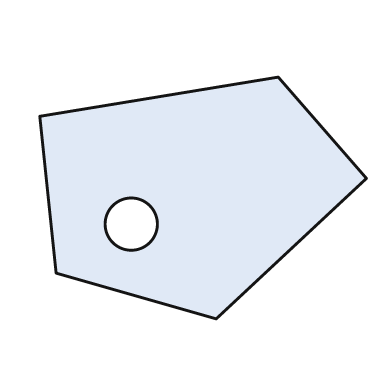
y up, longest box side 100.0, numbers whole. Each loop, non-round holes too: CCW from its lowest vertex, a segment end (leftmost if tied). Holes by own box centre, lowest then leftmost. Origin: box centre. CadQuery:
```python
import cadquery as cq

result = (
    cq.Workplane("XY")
    .moveTo(4.0, -37.0)
    .lineTo(50.0, 6.0)
    .lineTo(23.0, 37.0)
    .lineTo(-50.0, 25.0)
    .lineTo(-45.0, -23.0)
    .close()
    .moveTo(-22.0, -8.0)
    .circle(8.0)
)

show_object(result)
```